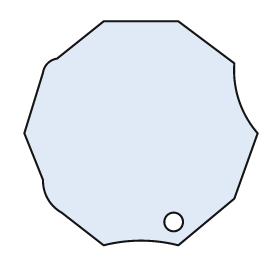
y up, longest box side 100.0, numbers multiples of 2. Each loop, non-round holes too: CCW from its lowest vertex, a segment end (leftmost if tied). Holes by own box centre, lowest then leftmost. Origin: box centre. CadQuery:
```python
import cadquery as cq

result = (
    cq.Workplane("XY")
    .moveTo(-16.0, -48.0)
    .threePointArc((0.0, -46.0), (16.0, -48.0))
    .lineTo(40.0, -28.0)
    .lineTo(50.0, 0.0)
    .threePointArc((42.0, 14.0), (40.0, 30.0))
    .lineTo(16.0, 48.0)
    .lineTo(-16.0, 48.0)
    .lineTo(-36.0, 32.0)
    .threePointArc((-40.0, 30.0), (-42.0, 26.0))
    .lineTo(-50.0, 0.0)
    .lineTo(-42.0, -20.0)
    .threePointArc((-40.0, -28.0), (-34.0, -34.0))
    .close()
    .moveTo(14.0, -38.0)
    .circle(4.0)
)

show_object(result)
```